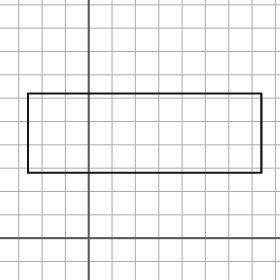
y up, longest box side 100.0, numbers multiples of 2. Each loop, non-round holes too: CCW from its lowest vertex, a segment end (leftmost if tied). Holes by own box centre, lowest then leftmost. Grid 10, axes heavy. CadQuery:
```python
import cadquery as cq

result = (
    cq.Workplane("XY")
    .moveTo(-26.0, 28.0)
    .lineTo(74.0, 28.0)
    .lineTo(74.0, 62.0)
    .lineTo(-26.0, 62.0)
    .close()
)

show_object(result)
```